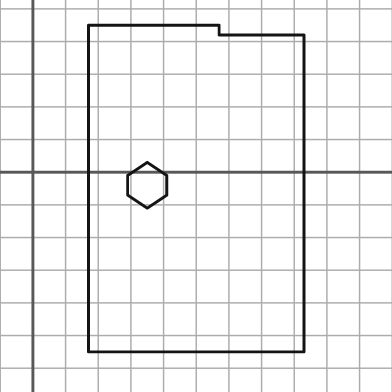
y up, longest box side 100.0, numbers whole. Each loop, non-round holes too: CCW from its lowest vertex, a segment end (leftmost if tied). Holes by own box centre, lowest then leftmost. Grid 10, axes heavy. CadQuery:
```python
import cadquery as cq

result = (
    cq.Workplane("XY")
    .moveTo(17.0, -55.0)
    .lineTo(83.0, -55.0)
    .lineTo(83.0, 42.0)
    .lineTo(57.0, 42.0)
    .lineTo(57.0, 45.0)
    .lineTo(17.0, 45.0)
    .close()
    .moveTo(35.0, -11.0)
    .lineTo(41.0, -7.0)
    .lineTo(41.0, -1.0)
    .lineTo(35.0, 3.0)
    .lineTo(29.0, -1.0)
    .lineTo(29.0, -7.0)
    .close()
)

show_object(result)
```